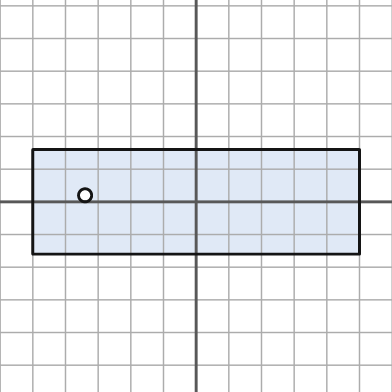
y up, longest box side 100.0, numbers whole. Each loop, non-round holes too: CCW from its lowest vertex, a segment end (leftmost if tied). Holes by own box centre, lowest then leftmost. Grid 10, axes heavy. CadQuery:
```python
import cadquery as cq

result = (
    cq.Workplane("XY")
    .moveTo(-50.0, -16.0)
    .lineTo(50.0, -16.0)
    .lineTo(50.0, 16.0)
    .lineTo(-50.0, 16.0)
    .close()
    .moveTo(-34.0, 2.0)
    .circle(2.0)
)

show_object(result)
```